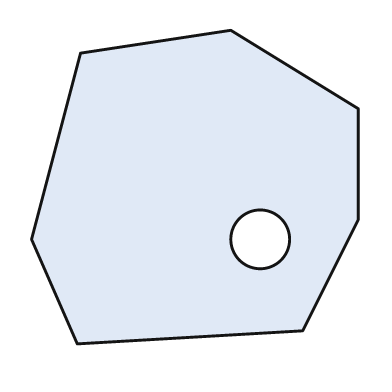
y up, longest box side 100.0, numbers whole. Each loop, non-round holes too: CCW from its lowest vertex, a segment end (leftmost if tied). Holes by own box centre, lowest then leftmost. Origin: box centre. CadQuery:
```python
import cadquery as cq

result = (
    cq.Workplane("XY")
    .moveTo(-36.0, -48.0)
    .lineTo(33.0, -44.0)
    .lineTo(50.0, -10.0)
    .lineTo(50.0, 24.0)
    .lineTo(11.0, 48.0)
    .lineTo(-35.0, 41.0)
    .lineTo(-50.0, -16.0)
    .close()
    .moveTo(20.0, -16.0)
    .circle(9.0)
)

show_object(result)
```